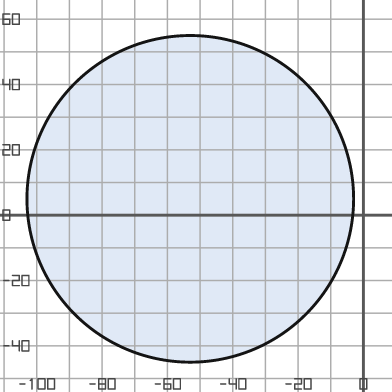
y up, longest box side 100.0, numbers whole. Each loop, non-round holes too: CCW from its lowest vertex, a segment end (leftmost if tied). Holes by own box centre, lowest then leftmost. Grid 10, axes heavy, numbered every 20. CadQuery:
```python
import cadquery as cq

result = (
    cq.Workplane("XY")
    .moveTo(-53.0, 5.0)
    .circle(50.0)
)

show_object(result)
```